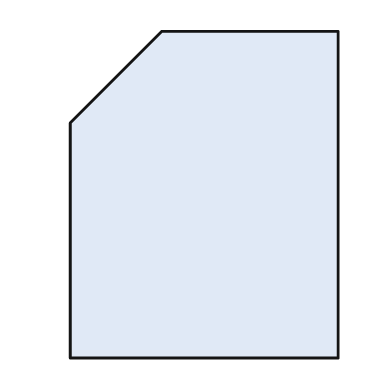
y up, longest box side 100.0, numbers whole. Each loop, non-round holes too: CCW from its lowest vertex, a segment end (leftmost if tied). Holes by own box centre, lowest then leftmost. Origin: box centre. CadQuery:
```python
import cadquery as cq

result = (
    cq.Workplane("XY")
    .moveTo(-41.0, -50.0)
    .lineTo(41.0, -50.0)
    .lineTo(41.0, 50.0)
    .lineTo(-13.0, 50.0)
    .lineTo(-41.0, 22.0)
    .close()
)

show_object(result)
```